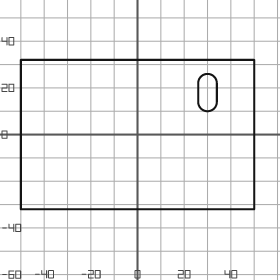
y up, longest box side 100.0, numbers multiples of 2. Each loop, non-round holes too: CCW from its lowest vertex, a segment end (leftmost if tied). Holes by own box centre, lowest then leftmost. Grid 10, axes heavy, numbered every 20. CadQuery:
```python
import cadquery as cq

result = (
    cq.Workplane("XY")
    .moveTo(-50.0, -32.0)
    .lineTo(50.0, -32.0)
    .lineTo(50.0, 32.0)
    .lineTo(-50.0, 32.0)
    .close()
    .moveTo(26.0, 14.0)
    .threePointArc((30.0, 10.0), (34.0, 14.0))
    .lineTo(34.0, 22.0)
    .threePointArc((30.0, 26.0), (26.0, 22.0))
    .close()
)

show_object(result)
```